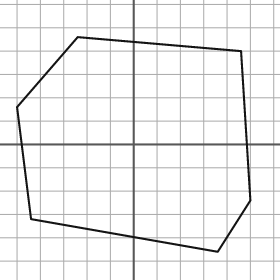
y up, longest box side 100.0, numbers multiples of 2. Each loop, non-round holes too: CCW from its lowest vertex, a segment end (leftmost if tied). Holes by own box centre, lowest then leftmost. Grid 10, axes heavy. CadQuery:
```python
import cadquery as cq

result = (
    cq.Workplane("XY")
    .moveTo(36.0, -46.0)
    .lineTo(50.0, -24.0)
    .lineTo(46.0, 40.0)
    .lineTo(-24.0, 46.0)
    .lineTo(-50.0, 16.0)
    .lineTo(-44.0, -32.0)
    .close()
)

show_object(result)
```